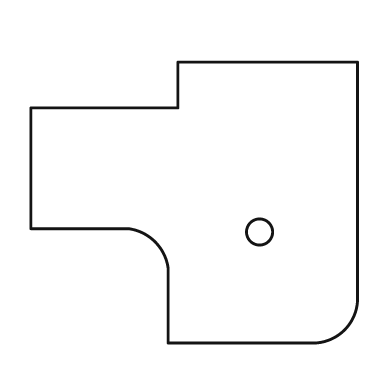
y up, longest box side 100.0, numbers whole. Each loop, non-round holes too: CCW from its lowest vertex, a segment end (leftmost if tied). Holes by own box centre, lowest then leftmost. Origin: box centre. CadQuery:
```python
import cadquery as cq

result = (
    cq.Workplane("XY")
    .moveTo(-8.0, -43.0)
    .lineTo(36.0, -43.0)
    .threePointArc((46.0, -39.0), (50.0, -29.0))
    .lineTo(50.0, 43.0)
    .lineTo(-5.0, 43.0)
    .lineTo(-5.0, 29.0)
    .lineTo(-50.0, 29.0)
    .lineTo(-50.0, -8.0)
    .lineTo(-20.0, -8.0)
    .threePointArc((-12.0, -12.0), (-8.0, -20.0))
    .close()
    .moveTo(20.0, -9.0)
    .circle(4.0)
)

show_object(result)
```